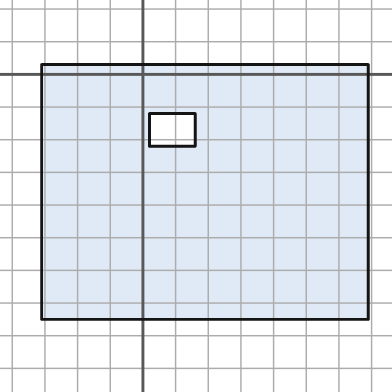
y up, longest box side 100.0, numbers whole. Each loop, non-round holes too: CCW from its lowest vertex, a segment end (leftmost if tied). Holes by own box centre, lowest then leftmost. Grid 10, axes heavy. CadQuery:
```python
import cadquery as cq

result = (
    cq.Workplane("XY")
    .moveTo(-31.0, -75.0)
    .lineTo(69.0, -75.0)
    .lineTo(69.0, 3.0)
    .lineTo(-31.0, 3.0)
    .close()
    .moveTo(2.0, -22.0)
    .lineTo(16.0, -22.0)
    .lineTo(16.0, -12.0)
    .lineTo(2.0, -12.0)
    .close()
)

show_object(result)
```